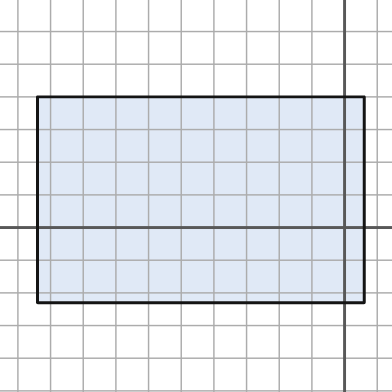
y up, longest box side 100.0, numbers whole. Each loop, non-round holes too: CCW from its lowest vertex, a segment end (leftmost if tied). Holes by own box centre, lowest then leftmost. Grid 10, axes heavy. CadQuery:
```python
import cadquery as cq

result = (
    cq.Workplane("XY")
    .moveTo(-94.0, -23.0)
    .lineTo(6.0, -23.0)
    .lineTo(6.0, 40.0)
    .lineTo(-94.0, 40.0)
    .close()
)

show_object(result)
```